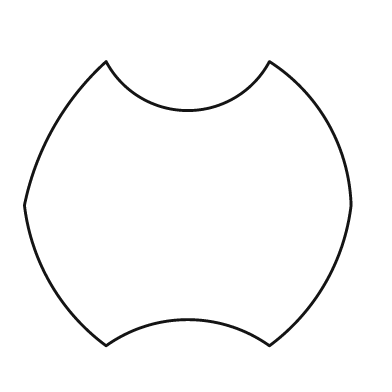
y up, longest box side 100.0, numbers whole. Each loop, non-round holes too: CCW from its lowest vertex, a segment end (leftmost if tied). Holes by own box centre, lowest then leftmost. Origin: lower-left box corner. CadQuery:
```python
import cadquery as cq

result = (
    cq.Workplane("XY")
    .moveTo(25.0, 0.0)
    .threePointArc((50.0, 8.0), (75.0, 0.0))
    .threePointArc((92.0, 19.0), (100.0, 43.0))
    .threePointArc((93.0, 68.0), (75.0, 87.0))
    .threePointArc((50.0, 72.0), (25.0, 87.0))
    .threePointArc((9.0, 67.0), (0.0, 43.0))
    .threePointArc((8.0, 19.0), (25.0, 0.0))
    .close()
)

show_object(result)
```